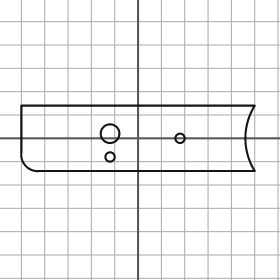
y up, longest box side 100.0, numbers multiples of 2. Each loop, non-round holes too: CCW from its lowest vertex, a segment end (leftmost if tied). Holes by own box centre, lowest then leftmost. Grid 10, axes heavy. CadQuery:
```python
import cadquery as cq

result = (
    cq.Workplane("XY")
    .moveTo(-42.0, -14.0)
    .lineTo(50.0, -14.0)
    .threePointArc((46.0, 0.0), (50.0, 14.0))
    .lineTo(-50.0, 14.0)
    .lineTo(-50.0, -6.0)
    .threePointArc((-48.0, -12.0), (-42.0, -14.0))
    .close()
    .moveTo(-12.0, -8.0)
    .circle(2.0)
    .moveTo(18.0, 0.0)
    .circle(2.0)
    .moveTo(-12.0, 2.0)
    .circle(4.0)
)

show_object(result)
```